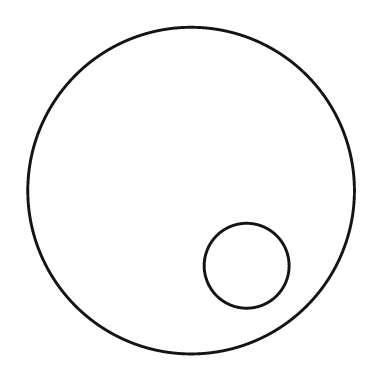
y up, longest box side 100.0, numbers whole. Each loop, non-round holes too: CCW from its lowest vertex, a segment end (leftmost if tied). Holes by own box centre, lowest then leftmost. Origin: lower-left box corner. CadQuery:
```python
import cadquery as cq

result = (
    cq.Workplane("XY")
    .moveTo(50.0, 50.0)
    .circle(50.0)
    .moveTo(67.0, 27.0)
    .circle(13.0)
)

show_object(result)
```